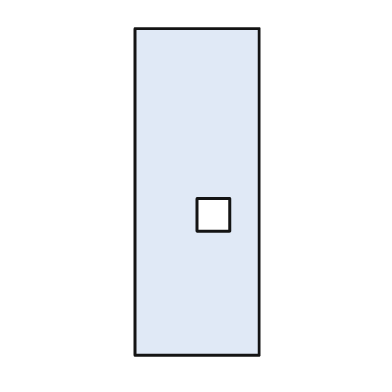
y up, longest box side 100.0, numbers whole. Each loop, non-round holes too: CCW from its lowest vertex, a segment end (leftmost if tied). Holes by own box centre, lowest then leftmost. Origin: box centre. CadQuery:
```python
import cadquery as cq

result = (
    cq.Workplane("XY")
    .moveTo(-19.0, -50.0)
    .lineTo(19.0, -50.0)
    .lineTo(19.0, 50.0)
    .lineTo(-19.0, 50.0)
    .close()
    .moveTo(0.0, -12.0)
    .lineTo(10.0, -12.0)
    .lineTo(10.0, -2.0)
    .lineTo(0.0, -2.0)
    .close()
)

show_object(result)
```